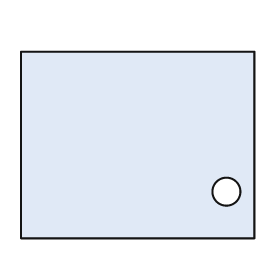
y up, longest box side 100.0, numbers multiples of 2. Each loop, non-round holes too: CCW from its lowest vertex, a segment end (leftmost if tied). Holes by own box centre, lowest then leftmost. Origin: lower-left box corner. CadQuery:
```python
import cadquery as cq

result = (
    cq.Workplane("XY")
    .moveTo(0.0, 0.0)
    .lineTo(100.0, 0.0)
    .lineTo(100.0, 80.0)
    .lineTo(0.0, 80.0)
    .close()
    .moveTo(88.0, 20.0)
    .circle(6.0)
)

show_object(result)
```